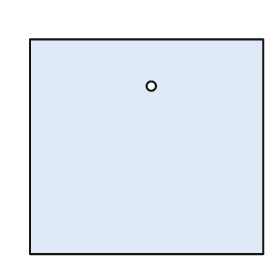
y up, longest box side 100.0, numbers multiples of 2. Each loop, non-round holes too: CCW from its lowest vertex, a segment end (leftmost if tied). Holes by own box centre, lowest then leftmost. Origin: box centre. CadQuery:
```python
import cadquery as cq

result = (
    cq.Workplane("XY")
    .moveTo(-50.0, -46.0)
    .lineTo(50.0, -46.0)
    .lineTo(50.0, 46.0)
    .lineTo(-50.0, 46.0)
    .close()
    .moveTo(2.0, 26.0)
    .circle(2.0)
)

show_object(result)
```